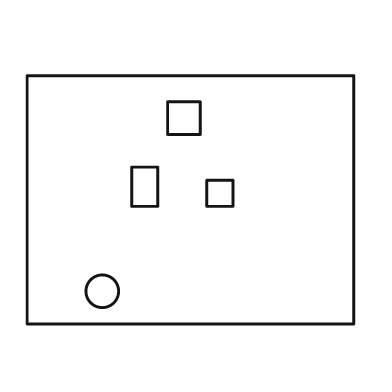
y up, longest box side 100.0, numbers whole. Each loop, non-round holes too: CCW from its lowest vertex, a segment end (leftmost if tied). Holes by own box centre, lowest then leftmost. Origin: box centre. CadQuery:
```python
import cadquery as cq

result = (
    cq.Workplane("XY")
    .moveTo(-50.0, -38.0)
    .lineTo(50.0, -38.0)
    .lineTo(50.0, 38.0)
    .lineTo(-50.0, 38.0)
    .close()
    .moveTo(-27.0, -28.0)
    .circle(5.0)
    .moveTo(5.0, -2.0)
    .lineTo(13.0, -2.0)
    .lineTo(13.0, 6.0)
    .lineTo(5.0, 6.0)
    .close()
    .moveTo(-18.0, -2.0)
    .lineTo(-10.0, -2.0)
    .lineTo(-10.0, 10.0)
    .lineTo(-18.0, 10.0)
    .close()
    .moveTo(-7.0, 20.0)
    .lineTo(3.0, 20.0)
    .lineTo(3.0, 30.0)
    .lineTo(-7.0, 30.0)
    .close()
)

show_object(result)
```